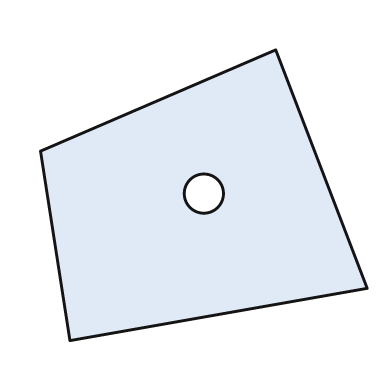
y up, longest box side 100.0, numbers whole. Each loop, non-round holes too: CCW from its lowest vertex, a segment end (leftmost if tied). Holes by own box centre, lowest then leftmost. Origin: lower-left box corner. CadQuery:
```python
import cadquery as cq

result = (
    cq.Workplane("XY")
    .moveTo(9.0, 0.0)
    .lineTo(100.0, 16.0)
    .lineTo(72.0, 89.0)
    .lineTo(0.0, 58.0)
    .close()
    .moveTo(50.0, 45.0)
    .circle(6.0)
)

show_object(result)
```